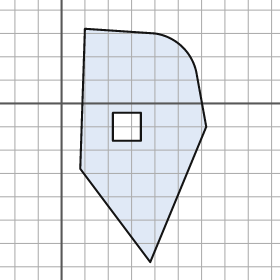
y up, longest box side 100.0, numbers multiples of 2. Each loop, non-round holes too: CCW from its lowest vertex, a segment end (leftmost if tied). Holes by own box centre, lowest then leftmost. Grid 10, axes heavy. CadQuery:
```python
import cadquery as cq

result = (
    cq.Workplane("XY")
    .moveTo(38.0, -68.0)
    .lineTo(62.0, -10.0)
    .lineTo(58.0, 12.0)
    .threePointArc((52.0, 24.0), (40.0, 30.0))
    .lineTo(10.0, 32.0)
    .lineTo(8.0, -28.0)
    .close()
    .moveTo(22.0, -16.0)
    .lineTo(34.0, -16.0)
    .lineTo(34.0, -4.0)
    .lineTo(22.0, -4.0)
    .close()
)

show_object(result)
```